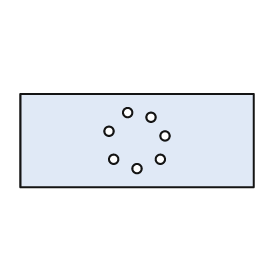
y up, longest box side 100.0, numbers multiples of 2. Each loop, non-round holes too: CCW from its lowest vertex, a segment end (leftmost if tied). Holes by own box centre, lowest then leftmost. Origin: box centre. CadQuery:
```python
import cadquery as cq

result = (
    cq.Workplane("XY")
    .moveTo(-50.0, -20.0)
    .lineTo(50.0, -20.0)
    .lineTo(50.0, 20.0)
    .lineTo(-50.0, 20.0)
    .close()
    .moveTo(0.0, -12.0)
    .circle(2.0)
    .moveTo(-10.0, -8.0)
    .circle(2.0)
    .moveTo(10.0, -8.0)
    .circle(2.0)
    .moveTo(12.0, 2.0)
    .circle(2.0)
    .moveTo(-12.0, 4.0)
    .circle(2.0)
    .moveTo(6.0, 10.0)
    .circle(2.0)
    .moveTo(-4.0, 12.0)
    .circle(2.0)
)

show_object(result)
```